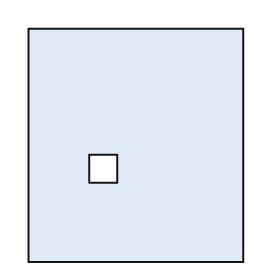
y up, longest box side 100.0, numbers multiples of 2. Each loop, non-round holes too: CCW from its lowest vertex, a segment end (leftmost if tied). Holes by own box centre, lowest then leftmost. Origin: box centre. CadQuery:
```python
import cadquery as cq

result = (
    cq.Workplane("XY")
    .moveTo(-46.0, -50.0)
    .lineTo(46.0, -50.0)
    .lineTo(46.0, 50.0)
    .lineTo(-46.0, 50.0)
    .close()
    .moveTo(-20.0, -16.0)
    .lineTo(-8.0, -16.0)
    .lineTo(-8.0, -4.0)
    .lineTo(-20.0, -4.0)
    .close()
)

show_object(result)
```